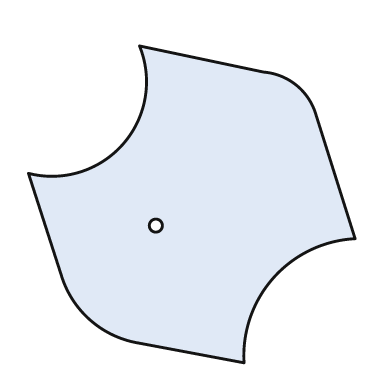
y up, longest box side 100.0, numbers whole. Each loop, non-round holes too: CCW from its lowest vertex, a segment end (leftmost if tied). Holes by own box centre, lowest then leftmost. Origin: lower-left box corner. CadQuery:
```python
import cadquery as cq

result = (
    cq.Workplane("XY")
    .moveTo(66.0, 0.0)
    .threePointArc((75.0, 26.0), (100.0, 38.0))
    .lineTo(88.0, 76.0)
    .threePointArc((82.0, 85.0), (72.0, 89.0))
    .lineTo(34.0, 97.0)
    .threePointArc((29.0, 67.0), (0.0, 58.0))
    .lineTo(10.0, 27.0)
    .threePointArc((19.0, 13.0), (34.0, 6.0))
    .close()
    .moveTo(39.0, 42.0)
    .circle(2.0)
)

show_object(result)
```